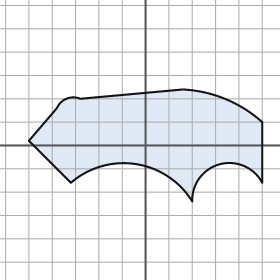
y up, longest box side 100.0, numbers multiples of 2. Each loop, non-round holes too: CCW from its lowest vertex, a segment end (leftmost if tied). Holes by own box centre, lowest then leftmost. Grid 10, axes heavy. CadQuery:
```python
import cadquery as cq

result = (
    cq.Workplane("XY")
    .moveTo(20.0, -24.0)
    .threePointArc((32.0, -8.0), (50.0, -16.0))
    .lineTo(50.0, 10.0)
    .threePointArc((34.0, 20.0), (16.0, 24.0))
    .lineTo(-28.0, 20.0)
    .threePointArc((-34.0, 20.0), (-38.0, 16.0))
    .lineTo(-50.0, 2.0)
    .lineTo(-32.0, -16.0)
    .threePointArc((-4.0, -8.0), (20.0, -24.0))
    .close()
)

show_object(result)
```